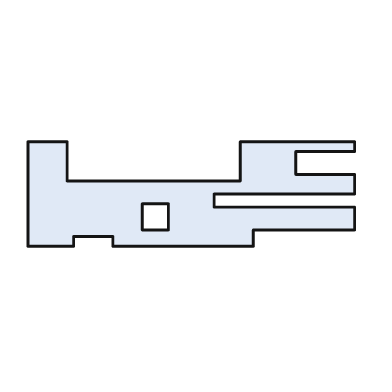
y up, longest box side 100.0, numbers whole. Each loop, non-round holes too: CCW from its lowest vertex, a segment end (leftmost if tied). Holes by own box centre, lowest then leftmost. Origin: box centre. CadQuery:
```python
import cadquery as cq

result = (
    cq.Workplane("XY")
    .moveTo(-50.0, -16.0)
    .lineTo(-36.0, -16.0)
    .lineTo(-36.0, -13.0)
    .lineTo(-24.0, -13.0)
    .lineTo(-24.0, -16.0)
    .lineTo(19.0, -16.0)
    .lineTo(19.0, -11.0)
    .lineTo(50.0, -11.0)
    .lineTo(50.0, -4.0)
    .lineTo(7.0, -4.0)
    .lineTo(7.0, 0.0)
    .lineTo(50.0, 0.0)
    .lineTo(50.0, 6.0)
    .lineTo(32.0, 6.0)
    .lineTo(32.0, 13.0)
    .lineTo(50.0, 13.0)
    .lineTo(50.0, 16.0)
    .lineTo(15.0, 16.0)
    .lineTo(15.0, 4.0)
    .lineTo(-38.0, 4.0)
    .lineTo(-38.0, 16.0)
    .lineTo(-50.0, 16.0)
    .close()
    .moveTo(-15.0, -11.0)
    .lineTo(-7.0, -11.0)
    .lineTo(-7.0, -3.0)
    .lineTo(-15.0, -3.0)
    .close()
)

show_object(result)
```